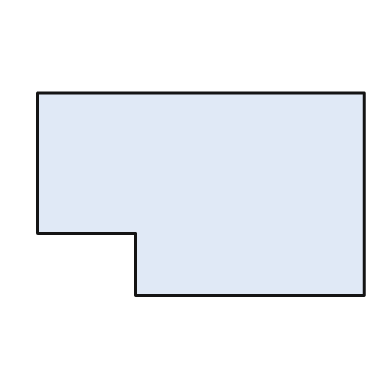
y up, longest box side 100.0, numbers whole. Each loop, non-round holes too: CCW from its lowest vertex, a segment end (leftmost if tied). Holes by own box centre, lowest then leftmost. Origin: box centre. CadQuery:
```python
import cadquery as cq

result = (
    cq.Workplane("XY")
    .moveTo(-20.0, -31.0)
    .lineTo(50.0, -31.0)
    .lineTo(50.0, 31.0)
    .lineTo(-50.0, 31.0)
    .lineTo(-50.0, -12.0)
    .lineTo(-20.0, -12.0)
    .close()
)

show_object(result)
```